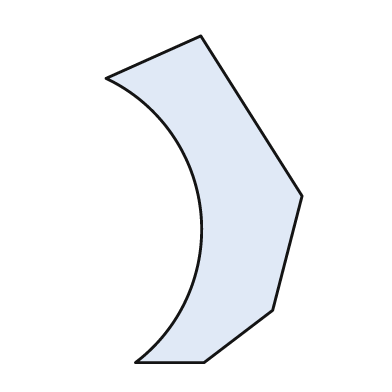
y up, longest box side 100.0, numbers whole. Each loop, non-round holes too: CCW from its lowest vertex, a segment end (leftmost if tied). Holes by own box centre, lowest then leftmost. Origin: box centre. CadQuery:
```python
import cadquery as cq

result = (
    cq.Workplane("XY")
    .moveTo(-21.0, -50.0)
    .lineTo(0.0, -50.0)
    .lineTo(21.0, -34.0)
    .lineTo(30.0, 1.0)
    .lineTo(-1.0, 50.0)
    .lineTo(-30.0, 37.0)
    .threePointArc((-1.0, -4.0), (-21.0, -50.0))
    .close()
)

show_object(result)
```